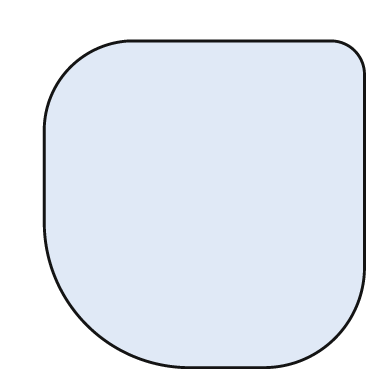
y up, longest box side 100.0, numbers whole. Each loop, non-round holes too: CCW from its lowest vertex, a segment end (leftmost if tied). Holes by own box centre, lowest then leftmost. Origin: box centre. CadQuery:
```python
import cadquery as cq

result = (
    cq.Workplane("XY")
    .moveTo(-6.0, -50.0)
    .lineTo(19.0, -50.0)
    .threePointArc((40.0, -41.0), (49.0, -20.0))
    .lineTo(49.0, 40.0)
    .threePointArc((46.0, 47.0), (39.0, 50.0))
    .lineTo(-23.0, 50.0)
    .threePointArc((-41.0, 42.0), (-49.0, 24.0))
    .lineTo(-49.0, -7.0)
    .threePointArc((-36.0, -37.0), (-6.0, -50.0))
    .close()
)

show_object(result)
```